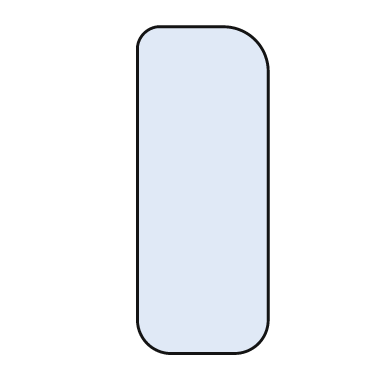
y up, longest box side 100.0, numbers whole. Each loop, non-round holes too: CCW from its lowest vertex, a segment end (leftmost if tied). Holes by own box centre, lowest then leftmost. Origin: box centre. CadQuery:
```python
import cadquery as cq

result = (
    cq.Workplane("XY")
    .moveTo(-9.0, -50.0)
    .lineTo(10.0, -50.0)
    .threePointArc((17.0, -47.0), (20.0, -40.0))
    .lineTo(20.0, 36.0)
    .threePointArc((16.0, 46.0), (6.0, 50.0))
    .lineTo(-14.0, 50.0)
    .threePointArc((-18.0, 48.0), (-20.0, 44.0))
    .lineTo(-20.0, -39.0)
    .threePointArc((-17.0, -47.0), (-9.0, -50.0))
    .close()
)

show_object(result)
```